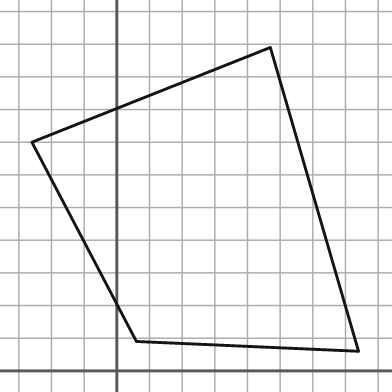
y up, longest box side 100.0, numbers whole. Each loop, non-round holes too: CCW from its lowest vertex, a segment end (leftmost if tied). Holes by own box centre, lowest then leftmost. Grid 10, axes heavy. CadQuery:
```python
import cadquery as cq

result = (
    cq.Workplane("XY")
    .moveTo(74.0, 6.0)
    .lineTo(47.0, 99.0)
    .lineTo(-26.0, 70.0)
    .lineTo(6.0, 9.0)
    .close()
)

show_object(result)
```